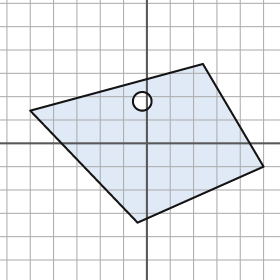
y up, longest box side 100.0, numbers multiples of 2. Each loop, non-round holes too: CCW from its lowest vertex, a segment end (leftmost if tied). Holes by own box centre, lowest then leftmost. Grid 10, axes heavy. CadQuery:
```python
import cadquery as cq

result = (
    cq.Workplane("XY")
    .moveTo(-4.0, -34.0)
    .lineTo(50.0, -10.0)
    .lineTo(24.0, 34.0)
    .lineTo(-50.0, 14.0)
    .close()
    .moveTo(-2.0, 18.0)
    .circle(4.0)
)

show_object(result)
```